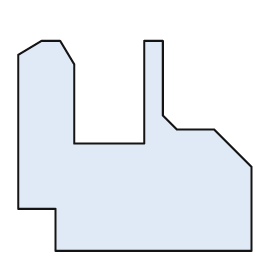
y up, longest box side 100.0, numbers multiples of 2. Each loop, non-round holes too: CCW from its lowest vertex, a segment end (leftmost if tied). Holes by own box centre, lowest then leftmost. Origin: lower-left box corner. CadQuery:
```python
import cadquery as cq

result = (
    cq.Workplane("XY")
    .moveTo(16.0, 0.0)
    .lineTo(100.0, 0.0)
    .lineTo(100.0, 36.0)
    .lineTo(84.0, 52.0)
    .lineTo(68.0, 52.0)
    .lineTo(62.0, 58.0)
    .lineTo(62.0, 90.0)
    .lineTo(54.0, 90.0)
    .lineTo(54.0, 46.0)
    .lineTo(24.0, 46.0)
    .lineTo(24.0, 80.0)
    .lineTo(18.0, 90.0)
    .lineTo(10.0, 90.0)
    .lineTo(0.0, 84.0)
    .lineTo(0.0, 18.0)
    .lineTo(16.0, 18.0)
    .close()
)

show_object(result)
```